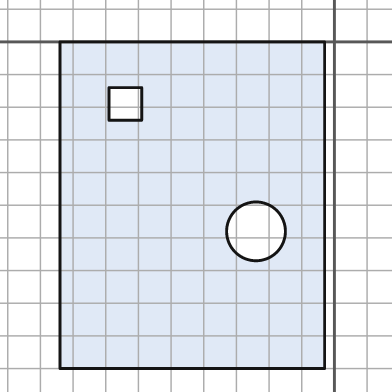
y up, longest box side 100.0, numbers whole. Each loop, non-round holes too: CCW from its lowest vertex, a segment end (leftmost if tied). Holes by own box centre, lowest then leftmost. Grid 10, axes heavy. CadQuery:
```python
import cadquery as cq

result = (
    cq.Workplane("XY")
    .moveTo(-84.0, -100.0)
    .lineTo(-3.0, -100.0)
    .lineTo(-3.0, 0.0)
    .lineTo(-84.0, 0.0)
    .close()
    .moveTo(-24.0, -58.0)
    .circle(9.0)
    .moveTo(-69.0, -24.0)
    .lineTo(-59.0, -24.0)
    .lineTo(-59.0, -14.0)
    .lineTo(-69.0, -14.0)
    .close()
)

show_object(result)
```